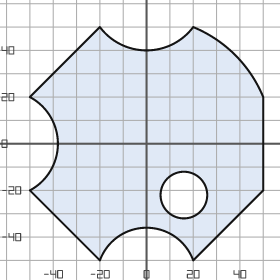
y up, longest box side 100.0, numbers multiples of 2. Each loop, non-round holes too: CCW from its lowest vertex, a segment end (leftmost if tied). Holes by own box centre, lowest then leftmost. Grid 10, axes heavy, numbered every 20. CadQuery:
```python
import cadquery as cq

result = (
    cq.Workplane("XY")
    .moveTo(-20.0, -50.0)
    .threePointArc((0.0, -36.0), (20.0, -50.0))
    .lineTo(50.0, -20.0)
    .lineTo(50.0, 20.0)
    .threePointArc((38.0, 38.0), (20.0, 50.0))
    .threePointArc((0.0, 40.0), (-20.0, 50.0))
    .lineTo(-50.0, 20.0)
    .threePointArc((-38.0, 0.0), (-50.0, -20.0))
    .close()
    .moveTo(16.0, -22.0)
    .circle(10.0)
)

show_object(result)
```